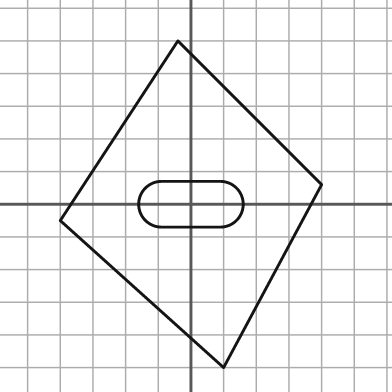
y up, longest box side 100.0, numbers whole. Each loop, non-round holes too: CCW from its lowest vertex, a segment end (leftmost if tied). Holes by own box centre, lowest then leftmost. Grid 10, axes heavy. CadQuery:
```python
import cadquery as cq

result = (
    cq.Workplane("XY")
    .moveTo(10.0, -50.0)
    .lineTo(40.0, 6.0)
    .lineTo(-4.0, 50.0)
    .lineTo(-40.0, -5.0)
    .close()
    .moveTo(-9.0, -7.0)
    .lineTo(9.0, -7.0)
    .threePointArc((16.0, 0.0), (9.0, 7.0))
    .lineTo(-9.0, 7.0)
    .threePointArc((-16.0, 0.0), (-9.0, -7.0))
    .close()
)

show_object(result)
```